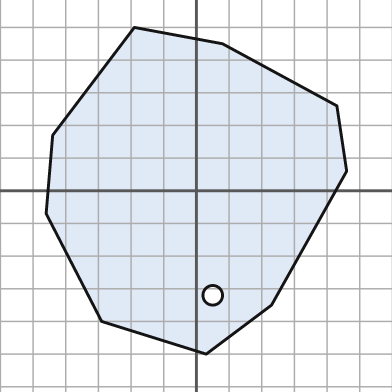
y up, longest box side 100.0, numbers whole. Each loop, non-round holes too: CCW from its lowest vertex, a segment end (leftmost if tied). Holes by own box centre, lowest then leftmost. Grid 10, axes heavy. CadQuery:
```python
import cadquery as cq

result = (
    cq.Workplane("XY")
    .moveTo(3.0, -50.0)
    .lineTo(23.0, -35.0)
    .lineTo(46.0, 6.0)
    .lineTo(43.0, 26.0)
    .lineTo(8.0, 45.0)
    .lineTo(-19.0, 50.0)
    .lineTo(-44.0, 17.0)
    .lineTo(-46.0, -7.0)
    .lineTo(-29.0, -40.0)
    .close()
    .moveTo(5.0, -32.0)
    .circle(3.0)
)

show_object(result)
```